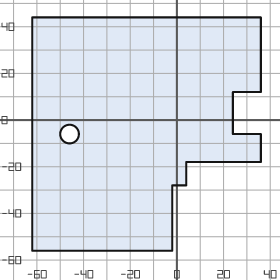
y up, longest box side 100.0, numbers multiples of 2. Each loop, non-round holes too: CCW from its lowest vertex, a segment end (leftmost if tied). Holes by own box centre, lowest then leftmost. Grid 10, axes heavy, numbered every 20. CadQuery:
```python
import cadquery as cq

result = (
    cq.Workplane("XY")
    .moveTo(-62.0, -56.0)
    .lineTo(-2.0, -56.0)
    .lineTo(-2.0, -28.0)
    .lineTo(4.0, -28.0)
    .lineTo(4.0, -18.0)
    .lineTo(36.0, -18.0)
    .lineTo(36.0, -6.0)
    .lineTo(24.0, -6.0)
    .lineTo(24.0, 12.0)
    .lineTo(36.0, 12.0)
    .lineTo(36.0, 44.0)
    .lineTo(-62.0, 44.0)
    .close()
    .moveTo(-46.0, -6.0)
    .circle(4.0)
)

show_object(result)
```